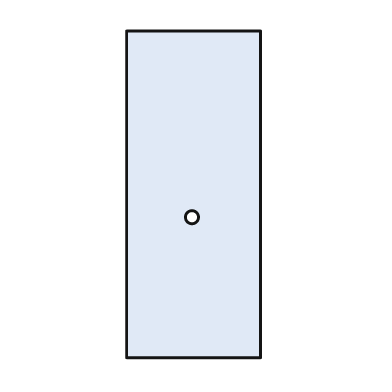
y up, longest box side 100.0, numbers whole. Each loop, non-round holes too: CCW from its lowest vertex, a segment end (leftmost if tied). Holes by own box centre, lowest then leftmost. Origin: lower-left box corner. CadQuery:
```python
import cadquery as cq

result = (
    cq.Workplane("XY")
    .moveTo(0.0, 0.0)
    .lineTo(41.0, 0.0)
    .lineTo(41.0, 100.0)
    .lineTo(0.0, 100.0)
    .close()
    .moveTo(20.0, 43.0)
    .circle(2.0)
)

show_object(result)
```